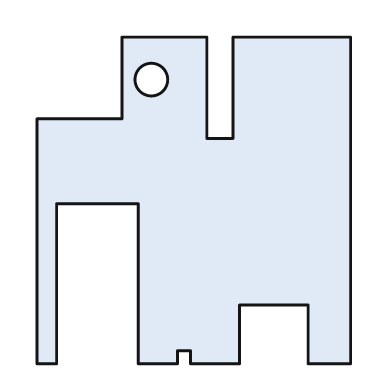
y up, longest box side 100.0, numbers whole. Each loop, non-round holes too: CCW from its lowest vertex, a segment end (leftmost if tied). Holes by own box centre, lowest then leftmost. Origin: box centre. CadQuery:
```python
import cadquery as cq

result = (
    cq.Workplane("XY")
    .moveTo(-48.0, -50.0)
    .lineTo(-42.0, -50.0)
    .lineTo(-42.0, -1.0)
    .lineTo(-17.0, -1.0)
    .lineTo(-17.0, -50.0)
    .lineTo(-5.0, -50.0)
    .lineTo(-5.0, -46.0)
    .lineTo(-1.0, -46.0)
    .lineTo(-1.0, -50.0)
    .lineTo(14.0, -50.0)
    .lineTo(14.0, -32.0)
    .lineTo(35.0, -32.0)
    .lineTo(35.0, -50.0)
    .lineTo(48.0, -50.0)
    .lineTo(48.0, 50.0)
    .lineTo(12.0, 50.0)
    .lineTo(12.0, 19.0)
    .lineTo(4.0, 19.0)
    .lineTo(4.0, 50.0)
    .lineTo(-22.0, 50.0)
    .lineTo(-22.0, 25.0)
    .lineTo(-48.0, 25.0)
    .close()
    .moveTo(-13.0, 37.0)
    .circle(5.0)
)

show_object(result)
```